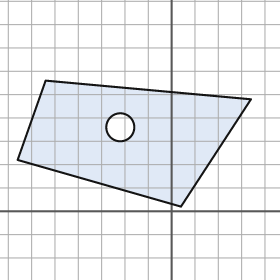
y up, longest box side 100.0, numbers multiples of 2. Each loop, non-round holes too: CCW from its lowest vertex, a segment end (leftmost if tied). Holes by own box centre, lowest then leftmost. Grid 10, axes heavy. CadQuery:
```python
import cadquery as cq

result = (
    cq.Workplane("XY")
    .moveTo(4.0, 2.0)
    .lineTo(34.0, 48.0)
    .lineTo(-54.0, 56.0)
    .lineTo(-66.0, 22.0)
    .close()
    .moveTo(-22.0, 36.0)
    .circle(6.0)
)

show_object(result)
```